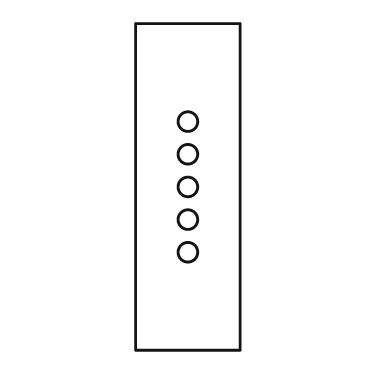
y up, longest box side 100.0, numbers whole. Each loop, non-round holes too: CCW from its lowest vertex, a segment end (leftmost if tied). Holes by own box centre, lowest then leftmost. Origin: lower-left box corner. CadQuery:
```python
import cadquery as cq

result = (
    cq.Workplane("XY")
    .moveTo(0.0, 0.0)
    .lineTo(32.0, 0.0)
    .lineTo(32.0, 100.0)
    .lineTo(0.0, 100.0)
    .close()
    .moveTo(16.0, 30.0)
    .circle(3.0)
    .moveTo(16.0, 40.0)
    .circle(3.0)
    .moveTo(16.0, 50.0)
    .circle(3.0)
    .moveTo(16.0, 60.0)
    .circle(3.0)
    .moveTo(16.0, 70.0)
    .circle(3.0)
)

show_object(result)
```